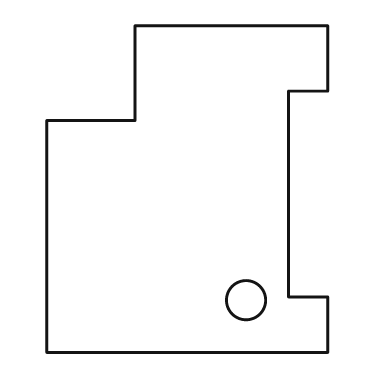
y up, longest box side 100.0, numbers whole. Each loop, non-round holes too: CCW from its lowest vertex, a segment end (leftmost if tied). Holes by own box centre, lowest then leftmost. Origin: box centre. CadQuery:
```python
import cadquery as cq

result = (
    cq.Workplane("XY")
    .moveTo(-43.0, -50.0)
    .lineTo(43.0, -50.0)
    .lineTo(43.0, -33.0)
    .lineTo(31.0, -33.0)
    .lineTo(31.0, 30.0)
    .lineTo(43.0, 30.0)
    .lineTo(43.0, 50.0)
    .lineTo(-16.0, 50.0)
    .lineTo(-16.0, 21.0)
    .lineTo(-43.0, 21.0)
    .close()
    .moveTo(18.0, -34.0)
    .circle(6.0)
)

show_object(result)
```